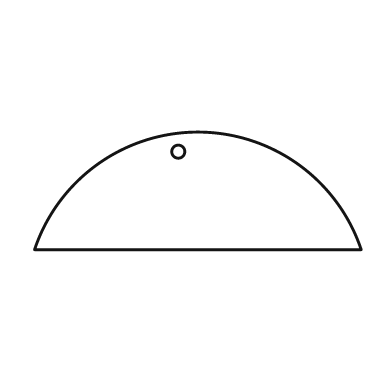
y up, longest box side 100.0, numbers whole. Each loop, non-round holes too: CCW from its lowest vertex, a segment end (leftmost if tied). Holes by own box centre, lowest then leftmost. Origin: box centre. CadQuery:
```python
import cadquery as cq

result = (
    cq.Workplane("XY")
    .moveTo(-50.0, -18.0)
    .lineTo(50.0, -18.0)
    .threePointArc((0.0, 18.0), (-50.0, -18.0))
    .close()
    .moveTo(-6.0, 12.0)
    .circle(2.0)
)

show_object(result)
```